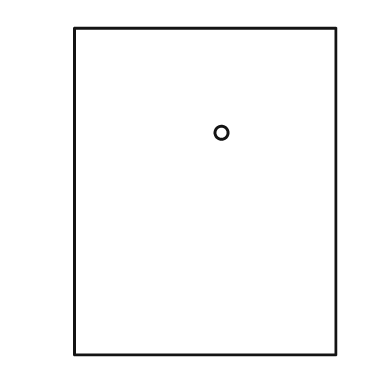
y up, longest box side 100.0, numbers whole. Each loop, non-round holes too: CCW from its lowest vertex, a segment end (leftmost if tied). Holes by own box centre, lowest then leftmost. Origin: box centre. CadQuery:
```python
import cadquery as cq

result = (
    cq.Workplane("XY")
    .moveTo(-40.0, -50.0)
    .lineTo(40.0, -50.0)
    .lineTo(40.0, 50.0)
    .lineTo(-40.0, 50.0)
    .close()
    .moveTo(5.0, 18.0)
    .circle(2.0)
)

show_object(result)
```